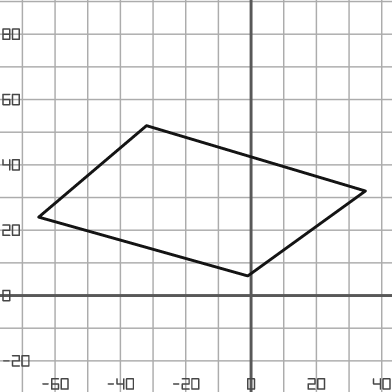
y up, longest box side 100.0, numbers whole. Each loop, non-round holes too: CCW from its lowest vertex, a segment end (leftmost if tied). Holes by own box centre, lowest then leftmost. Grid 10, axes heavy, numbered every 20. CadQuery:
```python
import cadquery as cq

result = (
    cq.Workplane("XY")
    .moveTo(-1.0, 6.0)
    .lineTo(35.0, 32.0)
    .lineTo(-32.0, 52.0)
    .lineTo(-65.0, 24.0)
    .close()
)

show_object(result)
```